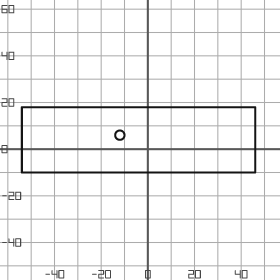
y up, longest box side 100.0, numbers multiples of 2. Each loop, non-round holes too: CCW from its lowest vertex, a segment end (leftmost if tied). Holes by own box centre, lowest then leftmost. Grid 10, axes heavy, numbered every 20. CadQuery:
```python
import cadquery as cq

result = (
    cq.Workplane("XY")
    .moveTo(-54.0, -10.0)
    .lineTo(46.0, -10.0)
    .lineTo(46.0, 18.0)
    .lineTo(-54.0, 18.0)
    .close()
    .moveTo(-12.0, 6.0)
    .circle(2.0)
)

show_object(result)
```